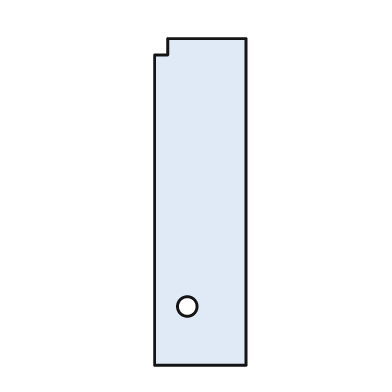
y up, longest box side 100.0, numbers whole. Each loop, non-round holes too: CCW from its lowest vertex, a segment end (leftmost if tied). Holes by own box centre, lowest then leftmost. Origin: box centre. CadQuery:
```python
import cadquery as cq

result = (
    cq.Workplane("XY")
    .moveTo(-14.0, -50.0)
    .lineTo(14.0, -50.0)
    .lineTo(14.0, 50.0)
    .lineTo(-10.0, 50.0)
    .lineTo(-10.0, 45.0)
    .lineTo(-14.0, 45.0)
    .close()
    .moveTo(-4.0, -32.0)
    .circle(3.0)
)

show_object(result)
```